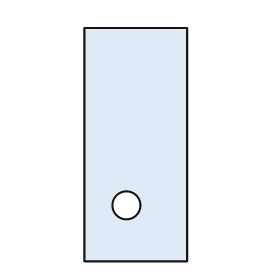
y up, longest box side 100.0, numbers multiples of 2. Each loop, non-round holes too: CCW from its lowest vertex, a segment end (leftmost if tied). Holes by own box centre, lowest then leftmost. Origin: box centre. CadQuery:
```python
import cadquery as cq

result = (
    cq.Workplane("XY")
    .moveTo(-22.0, -50.0)
    .lineTo(22.0, -50.0)
    .lineTo(22.0, 50.0)
    .lineTo(-22.0, 50.0)
    .close()
    .moveTo(-4.0, -26.0)
    .circle(6.0)
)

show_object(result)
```